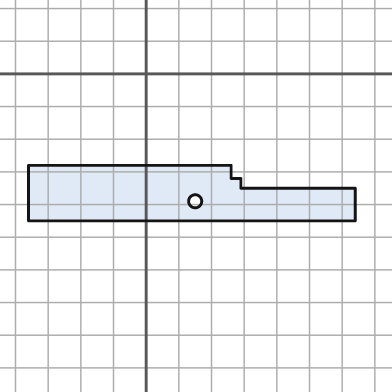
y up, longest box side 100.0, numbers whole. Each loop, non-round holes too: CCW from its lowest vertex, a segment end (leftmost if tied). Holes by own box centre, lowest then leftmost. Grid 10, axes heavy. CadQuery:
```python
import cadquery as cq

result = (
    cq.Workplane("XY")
    .moveTo(-36.0, -45.0)
    .lineTo(64.0, -45.0)
    .lineTo(64.0, -35.0)
    .lineTo(29.0, -35.0)
    .lineTo(29.0, -32.0)
    .lineTo(26.0, -32.0)
    .lineTo(26.0, -28.0)
    .lineTo(-36.0, -28.0)
    .close()
    .moveTo(15.0, -39.0)
    .circle(2.0)
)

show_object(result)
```